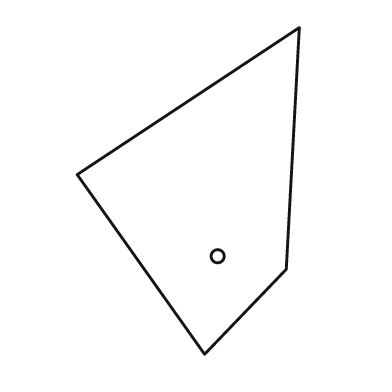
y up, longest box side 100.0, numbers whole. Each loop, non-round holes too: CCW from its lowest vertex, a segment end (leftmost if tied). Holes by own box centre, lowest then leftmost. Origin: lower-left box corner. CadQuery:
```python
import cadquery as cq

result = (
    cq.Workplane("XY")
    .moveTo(39.0, 0.0)
    .lineTo(64.0, 26.0)
    .lineTo(68.0, 100.0)
    .lineTo(0.0, 55.0)
    .close()
    .moveTo(43.0, 30.0)
    .circle(2.0)
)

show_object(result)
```